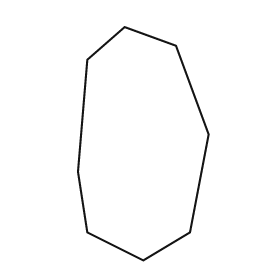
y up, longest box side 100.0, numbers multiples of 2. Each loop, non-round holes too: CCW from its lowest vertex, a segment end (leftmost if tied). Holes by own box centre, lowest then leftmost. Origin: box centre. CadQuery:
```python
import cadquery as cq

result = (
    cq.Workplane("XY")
    .moveTo(0.0, -50.0)
    .lineTo(20.0, -38.0)
    .lineTo(28.0, 4.0)
    .lineTo(14.0, 42.0)
    .lineTo(-8.0, 50.0)
    .lineTo(-24.0, 36.0)
    .lineTo(-28.0, -12.0)
    .lineTo(-24.0, -38.0)
    .close()
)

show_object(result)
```